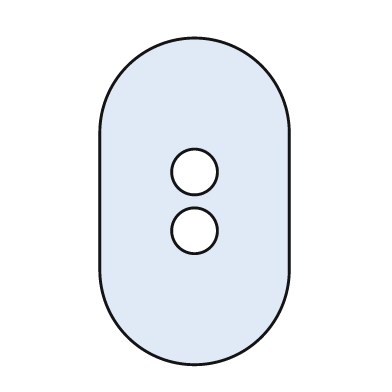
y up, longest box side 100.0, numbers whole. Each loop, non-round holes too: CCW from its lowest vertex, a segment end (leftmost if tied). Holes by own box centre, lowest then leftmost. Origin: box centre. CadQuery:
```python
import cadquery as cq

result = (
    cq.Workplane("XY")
    .moveTo(-29.0, -21.0)
    .threePointArc((0.0, -50.0), (29.0, -21.0))
    .lineTo(29.0, 21.0)
    .threePointArc((0.0, 50.0), (-29.0, 21.0))
    .close()
    .moveTo(0.0, -9.0)
    .circle(7.0)
    .moveTo(0.0, 9.0)
    .circle(7.0)
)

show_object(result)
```